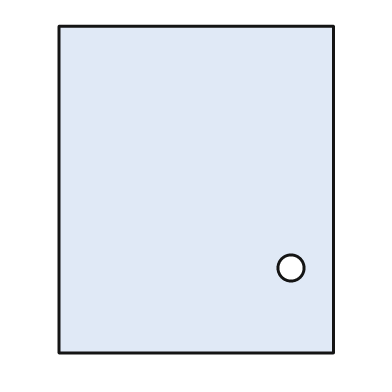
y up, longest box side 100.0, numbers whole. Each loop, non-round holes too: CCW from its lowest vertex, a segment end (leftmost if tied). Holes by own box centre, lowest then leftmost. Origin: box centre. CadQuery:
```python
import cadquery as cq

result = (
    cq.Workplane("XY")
    .moveTo(-42.0, -50.0)
    .lineTo(42.0, -50.0)
    .lineTo(42.0, 50.0)
    .lineTo(-42.0, 50.0)
    .close()
    .moveTo(29.0, -24.0)
    .circle(4.0)
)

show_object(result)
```